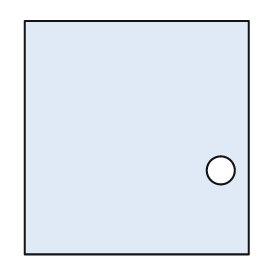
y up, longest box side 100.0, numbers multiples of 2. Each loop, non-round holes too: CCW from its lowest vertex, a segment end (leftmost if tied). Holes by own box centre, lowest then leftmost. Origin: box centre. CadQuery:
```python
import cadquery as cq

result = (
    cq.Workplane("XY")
    .moveTo(-48.0, -50.0)
    .lineTo(48.0, -50.0)
    .lineTo(48.0, 50.0)
    .lineTo(-48.0, 50.0)
    .close()
    .moveTo(36.0, -14.0)
    .circle(6.0)
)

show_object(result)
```